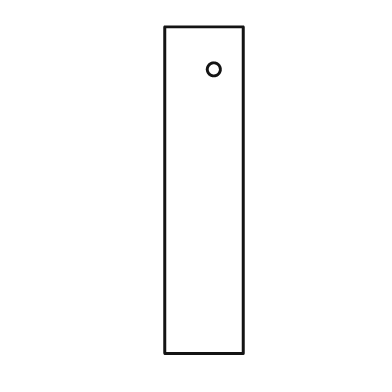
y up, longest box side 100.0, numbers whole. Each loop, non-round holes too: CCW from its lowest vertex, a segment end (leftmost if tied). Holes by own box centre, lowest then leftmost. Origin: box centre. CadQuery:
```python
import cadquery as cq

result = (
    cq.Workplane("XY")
    .moveTo(-12.0, -50.0)
    .lineTo(12.0, -50.0)
    .lineTo(12.0, 50.0)
    .lineTo(-12.0, 50.0)
    .close()
    .moveTo(3.0, 37.0)
    .circle(2.0)
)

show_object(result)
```